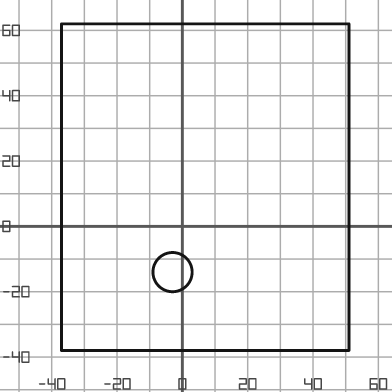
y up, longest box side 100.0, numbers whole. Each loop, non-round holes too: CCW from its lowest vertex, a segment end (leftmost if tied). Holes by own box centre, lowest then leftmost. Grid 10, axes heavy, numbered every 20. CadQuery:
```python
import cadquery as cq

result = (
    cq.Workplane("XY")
    .moveTo(-37.0, -38.0)
    .lineTo(51.0, -38.0)
    .lineTo(51.0, 62.0)
    .lineTo(-37.0, 62.0)
    .close()
    .moveTo(-3.0, -14.0)
    .circle(6.0)
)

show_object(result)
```